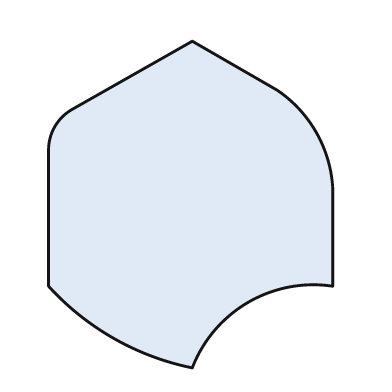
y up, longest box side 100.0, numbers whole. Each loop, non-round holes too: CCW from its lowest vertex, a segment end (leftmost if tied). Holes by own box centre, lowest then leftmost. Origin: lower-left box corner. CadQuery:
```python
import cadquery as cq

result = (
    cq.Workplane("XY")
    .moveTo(44.0, 0.0)
    .threePointArc((61.0, 20.0), (87.0, 25.0))
    .lineTo(87.0, 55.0)
    .threePointArc((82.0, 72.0), (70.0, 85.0))
    .lineTo(44.0, 100.0)
    .lineTo(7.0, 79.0)
    .threePointArc((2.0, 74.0), (0.0, 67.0))
    .lineTo(0.0, 25.0)
    .threePointArc((20.0, 9.0), (44.0, 0.0))
    .close()
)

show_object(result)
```